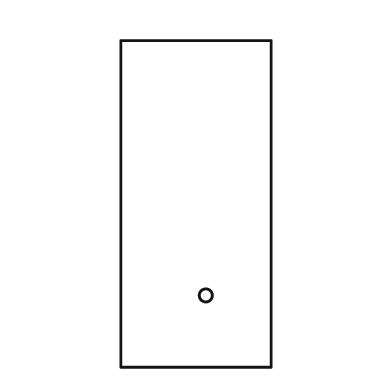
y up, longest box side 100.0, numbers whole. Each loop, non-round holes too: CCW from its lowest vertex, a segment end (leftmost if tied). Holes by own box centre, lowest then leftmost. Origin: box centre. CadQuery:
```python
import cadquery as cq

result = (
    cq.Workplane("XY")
    .moveTo(-23.0, -50.0)
    .lineTo(23.0, -50.0)
    .lineTo(23.0, 50.0)
    .lineTo(-23.0, 50.0)
    .close()
    .moveTo(3.0, -28.0)
    .circle(2.0)
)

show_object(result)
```